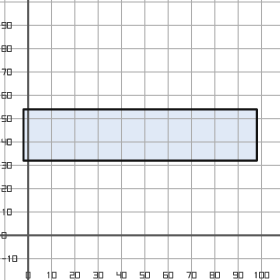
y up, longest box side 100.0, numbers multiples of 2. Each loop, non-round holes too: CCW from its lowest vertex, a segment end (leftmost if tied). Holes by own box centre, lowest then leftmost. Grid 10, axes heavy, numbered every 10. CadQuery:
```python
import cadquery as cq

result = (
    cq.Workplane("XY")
    .moveTo(-2.0, 32.0)
    .lineTo(98.0, 32.0)
    .lineTo(98.0, 54.0)
    .lineTo(-2.0, 54.0)
    .close()
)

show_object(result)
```